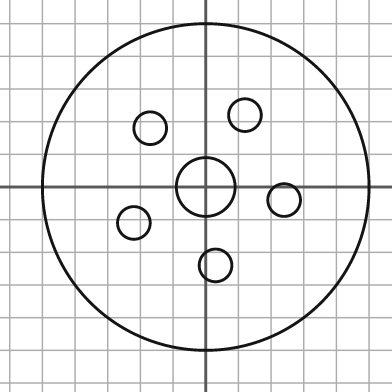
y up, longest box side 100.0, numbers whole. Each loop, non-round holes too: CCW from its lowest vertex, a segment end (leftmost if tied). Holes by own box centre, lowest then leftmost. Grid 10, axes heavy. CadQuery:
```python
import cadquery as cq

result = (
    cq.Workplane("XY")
    .moveTo(0.0, 0.0)
    .circle(50.0)
    .moveTo(3.0, -24.0)
    .circle(5.0)
    .moveTo(-22.0, -11.0)
    .circle(5.0)
    .moveTo(24.0, -4.0)
    .circle(5.0)
    .moveTo(0.0, 0.0)
    .circle(9.0)
    .moveTo(-17.0, 18.0)
    .circle(5.0)
    .moveTo(12.0, 22.0)
    .circle(5.0)
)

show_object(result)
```